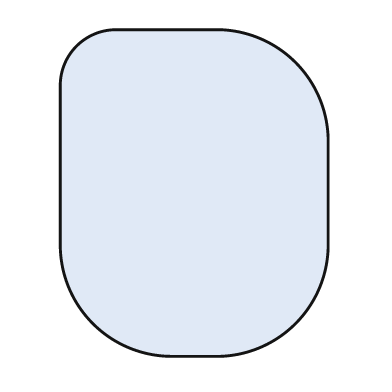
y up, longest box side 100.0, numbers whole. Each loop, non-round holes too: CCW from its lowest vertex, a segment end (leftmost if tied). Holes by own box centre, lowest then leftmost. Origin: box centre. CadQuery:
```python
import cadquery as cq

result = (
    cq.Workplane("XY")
    .moveTo(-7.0, -50.0)
    .lineTo(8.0, -50.0)
    .threePointArc((31.0, -40.0), (41.0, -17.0))
    .lineTo(41.0, 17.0)
    .threePointArc((31.0, 40.0), (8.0, 50.0))
    .lineTo(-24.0, 50.0)
    .threePointArc((-36.0, 45.0), (-41.0, 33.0))
    .lineTo(-41.0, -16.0)
    .threePointArc((-31.0, -40.0), (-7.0, -50.0))
    .close()
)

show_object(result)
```